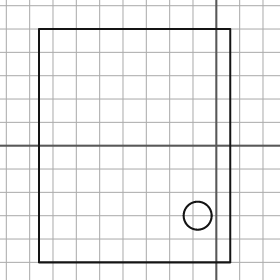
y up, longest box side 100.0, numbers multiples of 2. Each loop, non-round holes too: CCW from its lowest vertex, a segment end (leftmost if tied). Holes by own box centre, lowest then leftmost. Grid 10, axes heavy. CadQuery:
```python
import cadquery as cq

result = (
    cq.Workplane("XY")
    .moveTo(-76.0, -50.0)
    .lineTo(6.0, -50.0)
    .lineTo(6.0, 50.0)
    .lineTo(-76.0, 50.0)
    .close()
    .moveTo(-8.0, -30.0)
    .circle(6.0)
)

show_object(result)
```